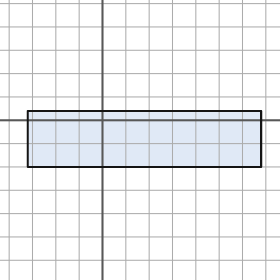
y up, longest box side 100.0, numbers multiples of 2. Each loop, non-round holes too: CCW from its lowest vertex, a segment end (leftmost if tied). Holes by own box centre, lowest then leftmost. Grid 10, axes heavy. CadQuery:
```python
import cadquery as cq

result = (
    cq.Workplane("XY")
    .moveTo(-32.0, -20.0)
    .lineTo(68.0, -20.0)
    .lineTo(68.0, 4.0)
    .lineTo(-32.0, 4.0)
    .close()
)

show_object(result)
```